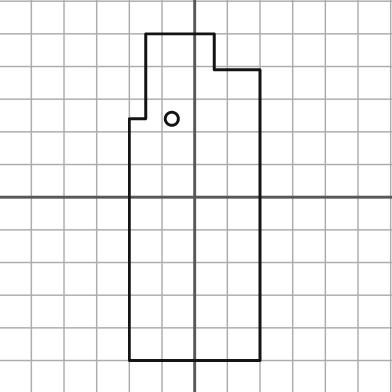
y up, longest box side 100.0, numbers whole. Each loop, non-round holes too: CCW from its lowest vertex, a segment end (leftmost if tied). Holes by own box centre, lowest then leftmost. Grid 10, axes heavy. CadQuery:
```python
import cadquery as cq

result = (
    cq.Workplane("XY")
    .moveTo(-20.0, -50.0)
    .lineTo(20.0, -50.0)
    .lineTo(20.0, 39.0)
    .lineTo(6.0, 39.0)
    .lineTo(6.0, 50.0)
    .lineTo(-15.0, 50.0)
    .lineTo(-15.0, 24.0)
    .lineTo(-20.0, 24.0)
    .close()
    .moveTo(-7.0, 24.0)
    .circle(2.0)
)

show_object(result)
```